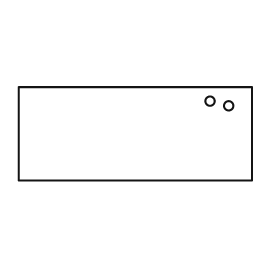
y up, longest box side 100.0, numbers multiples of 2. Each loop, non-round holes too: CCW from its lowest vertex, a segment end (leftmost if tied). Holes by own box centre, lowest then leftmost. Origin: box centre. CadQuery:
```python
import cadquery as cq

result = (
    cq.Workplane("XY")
    .moveTo(-50.0, -20.0)
    .lineTo(50.0, -20.0)
    .lineTo(50.0, 20.0)
    .lineTo(-50.0, 20.0)
    .close()
    .moveTo(40.0, 12.0)
    .circle(2.0)
    .moveTo(32.0, 14.0)
    .circle(2.0)
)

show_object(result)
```